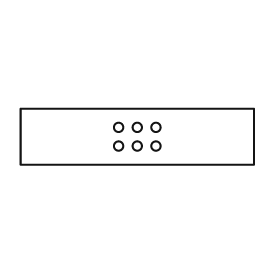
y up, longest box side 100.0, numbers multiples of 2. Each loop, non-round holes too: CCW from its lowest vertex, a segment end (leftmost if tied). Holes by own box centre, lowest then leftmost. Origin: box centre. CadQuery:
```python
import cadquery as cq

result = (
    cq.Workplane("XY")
    .moveTo(-50.0, -12.0)
    .lineTo(50.0, -12.0)
    .lineTo(50.0, 12.0)
    .lineTo(-50.0, 12.0)
    .close()
    .moveTo(-8.0, -4.0)
    .circle(2.0)
    .moveTo(0.0, -4.0)
    .circle(2.0)
    .moveTo(8.0, -4.0)
    .circle(2.0)
    .moveTo(-8.0, 4.0)
    .circle(2.0)
    .moveTo(0.0, 4.0)
    .circle(2.0)
    .moveTo(8.0, 4.0)
    .circle(2.0)
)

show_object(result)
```